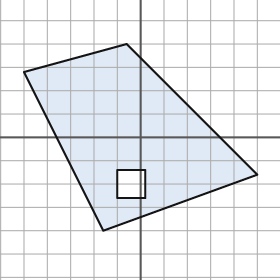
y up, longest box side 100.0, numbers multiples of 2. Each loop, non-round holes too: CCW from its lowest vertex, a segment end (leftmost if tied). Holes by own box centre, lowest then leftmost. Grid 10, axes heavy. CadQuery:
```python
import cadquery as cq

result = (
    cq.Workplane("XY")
    .moveTo(-16.0, -40.0)
    .lineTo(50.0, -16.0)
    .lineTo(-6.0, 40.0)
    .lineTo(-50.0, 28.0)
    .close()
    .moveTo(-10.0, -26.0)
    .lineTo(2.0, -26.0)
    .lineTo(2.0, -14.0)
    .lineTo(-10.0, -14.0)
    .close()
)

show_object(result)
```